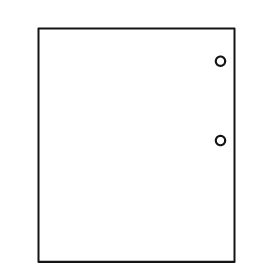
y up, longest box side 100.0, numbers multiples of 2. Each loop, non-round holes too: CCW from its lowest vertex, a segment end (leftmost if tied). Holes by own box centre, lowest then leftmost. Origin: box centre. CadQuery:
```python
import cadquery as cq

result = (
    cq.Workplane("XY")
    .moveTo(-42.0, -50.0)
    .lineTo(42.0, -50.0)
    .lineTo(42.0, 50.0)
    .lineTo(-42.0, 50.0)
    .close()
    .moveTo(36.0, 2.0)
    .circle(2.0)
    .moveTo(36.0, 36.0)
    .circle(2.0)
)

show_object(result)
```